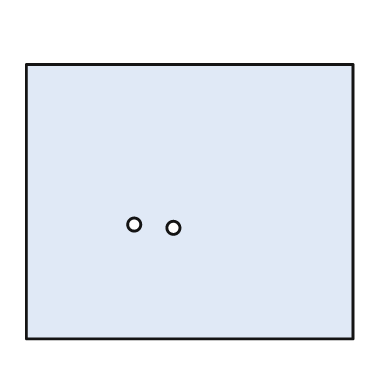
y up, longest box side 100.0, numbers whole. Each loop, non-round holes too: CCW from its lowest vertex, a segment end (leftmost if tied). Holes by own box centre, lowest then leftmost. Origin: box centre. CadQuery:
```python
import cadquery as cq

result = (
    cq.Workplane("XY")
    .moveTo(-50.0, -42.0)
    .lineTo(50.0, -42.0)
    .lineTo(50.0, 42.0)
    .lineTo(-50.0, 42.0)
    .close()
    .moveTo(-5.0, -8.0)
    .circle(2.0)
    .moveTo(-17.0, -7.0)
    .circle(2.0)
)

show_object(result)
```